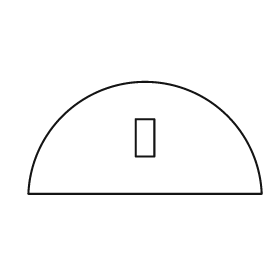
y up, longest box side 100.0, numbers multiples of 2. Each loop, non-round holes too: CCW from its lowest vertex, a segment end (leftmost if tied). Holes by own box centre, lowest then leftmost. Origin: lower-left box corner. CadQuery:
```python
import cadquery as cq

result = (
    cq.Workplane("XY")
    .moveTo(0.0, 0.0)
    .lineTo(100.0, 0.0)
    .threePointArc((50.0, 48.0), (0.0, 0.0))
    .close()
    .moveTo(46.0, 16.0)
    .lineTo(54.0, 16.0)
    .lineTo(54.0, 32.0)
    .lineTo(46.0, 32.0)
    .close()
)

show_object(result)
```